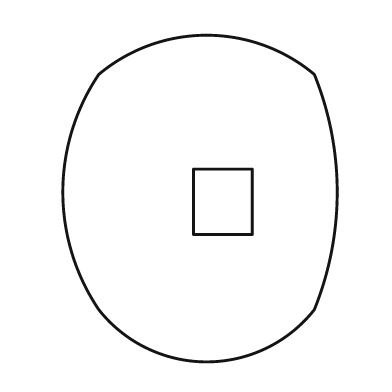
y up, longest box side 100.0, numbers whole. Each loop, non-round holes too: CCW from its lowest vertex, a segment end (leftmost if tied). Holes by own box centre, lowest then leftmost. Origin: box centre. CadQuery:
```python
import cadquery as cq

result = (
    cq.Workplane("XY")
    .moveTo(-31.0, -34.0)
    .threePointArc((2.0, -50.0), (35.0, -34.0))
    .threePointArc((42.0, 2.0), (35.0, 38.0))
    .threePointArc((2.0, 50.0), (-31.0, 38.0))
    .threePointArc((-42.0, 2.0), (-31.0, -34.0))
    .close()
    .moveTo(-2.0, -11.0)
    .lineTo(16.0, -11.0)
    .lineTo(16.0, 9.0)
    .lineTo(-2.0, 9.0)
    .close()
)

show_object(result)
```